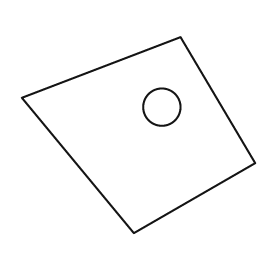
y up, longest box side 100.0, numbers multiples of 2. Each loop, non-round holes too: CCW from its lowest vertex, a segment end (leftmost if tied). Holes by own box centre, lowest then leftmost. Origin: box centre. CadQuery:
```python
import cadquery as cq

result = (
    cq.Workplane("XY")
    .moveTo(-2.0, -42.0)
    .lineTo(50.0, -12.0)
    .lineTo(18.0, 42.0)
    .lineTo(-50.0, 16.0)
    .close()
    .moveTo(10.0, 12.0)
    .circle(8.0)
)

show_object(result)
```